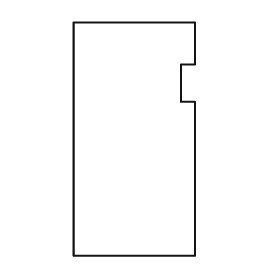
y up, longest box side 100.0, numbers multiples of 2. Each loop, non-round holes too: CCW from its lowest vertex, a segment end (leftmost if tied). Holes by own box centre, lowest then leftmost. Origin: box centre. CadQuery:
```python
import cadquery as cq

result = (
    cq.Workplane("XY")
    .moveTo(-26.0, -50.0)
    .lineTo(26.0, -50.0)
    .lineTo(26.0, 16.0)
    .lineTo(20.0, 16.0)
    .lineTo(20.0, 32.0)
    .lineTo(26.0, 32.0)
    .lineTo(26.0, 50.0)
    .lineTo(-26.0, 50.0)
    .close()
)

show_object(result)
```